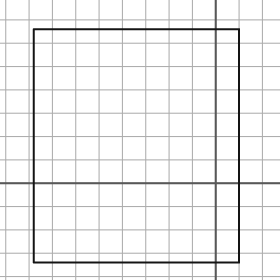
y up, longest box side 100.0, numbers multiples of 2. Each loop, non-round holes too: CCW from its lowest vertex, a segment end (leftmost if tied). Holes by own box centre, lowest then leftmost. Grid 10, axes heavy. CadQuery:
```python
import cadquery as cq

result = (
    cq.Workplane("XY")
    .moveTo(-78.0, -34.0)
    .lineTo(10.0, -34.0)
    .lineTo(10.0, 66.0)
    .lineTo(-78.0, 66.0)
    .close()
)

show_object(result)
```